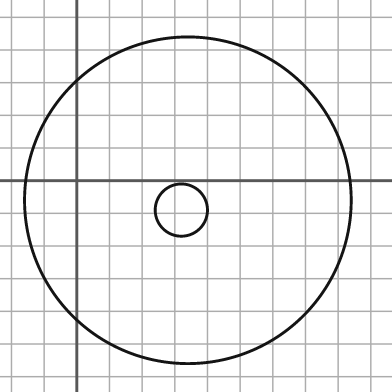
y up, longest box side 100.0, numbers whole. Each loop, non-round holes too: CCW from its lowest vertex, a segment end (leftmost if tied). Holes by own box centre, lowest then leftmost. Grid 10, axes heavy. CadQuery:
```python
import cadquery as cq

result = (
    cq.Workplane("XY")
    .moveTo(34.0, -6.0)
    .circle(50.0)
    .moveTo(32.0, -9.0)
    .circle(8.0)
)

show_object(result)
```